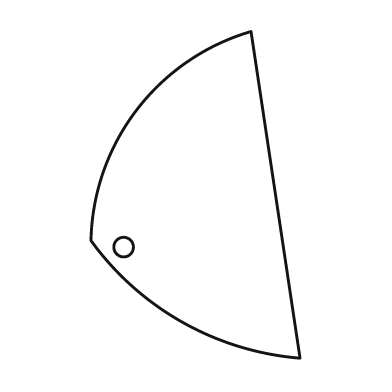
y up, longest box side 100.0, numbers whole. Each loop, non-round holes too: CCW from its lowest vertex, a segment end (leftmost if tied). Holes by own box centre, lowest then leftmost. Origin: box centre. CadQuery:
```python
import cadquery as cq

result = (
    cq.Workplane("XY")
    .moveTo(32.0, -50.0)
    .lineTo(17.0, 50.0)
    .threePointArc((-18.0, 26.0), (-32.0, -14.0))
    .threePointArc((-4.0, -39.0), (32.0, -50.0))
    .close()
    .moveTo(-22.0, -16.0)
    .circle(3.0)
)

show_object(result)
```